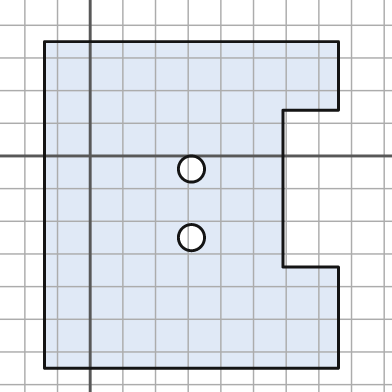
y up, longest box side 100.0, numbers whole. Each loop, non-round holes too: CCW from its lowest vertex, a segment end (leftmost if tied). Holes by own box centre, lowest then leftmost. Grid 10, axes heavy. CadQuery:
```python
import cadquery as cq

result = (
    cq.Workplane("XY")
    .moveTo(-14.0, -65.0)
    .lineTo(76.0, -65.0)
    .lineTo(76.0, -34.0)
    .lineTo(59.0, -34.0)
    .lineTo(59.0, 14.0)
    .lineTo(76.0, 14.0)
    .lineTo(76.0, 35.0)
    .lineTo(-14.0, 35.0)
    .close()
    .moveTo(31.0, -25.0)
    .circle(4.0)
    .moveTo(31.0, -4.0)
    .circle(4.0)
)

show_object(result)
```